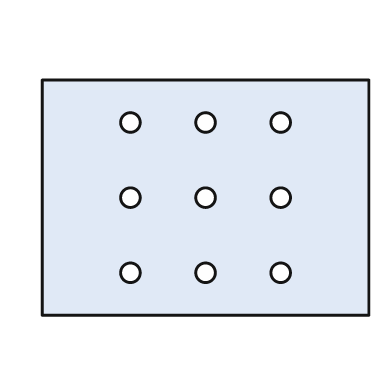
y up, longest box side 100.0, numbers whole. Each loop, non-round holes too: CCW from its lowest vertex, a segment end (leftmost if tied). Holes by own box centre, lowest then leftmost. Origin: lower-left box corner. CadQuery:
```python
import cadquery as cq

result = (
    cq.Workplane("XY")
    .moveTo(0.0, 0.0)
    .lineTo(100.0, 0.0)
    .lineTo(100.0, 72.0)
    .lineTo(0.0, 72.0)
    .close()
    .moveTo(27.0, 13.0)
    .circle(3.0)
    .moveTo(50.0, 13.0)
    .circle(3.0)
    .moveTo(73.0, 13.0)
    .circle(3.0)
    .moveTo(27.0, 36.0)
    .circle(3.0)
    .moveTo(50.0, 36.0)
    .circle(3.0)
    .moveTo(73.0, 36.0)
    .circle(3.0)
    .moveTo(27.0, 59.0)
    .circle(3.0)
    .moveTo(50.0, 59.0)
    .circle(3.0)
    .moveTo(73.0, 59.0)
    .circle(3.0)
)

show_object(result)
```